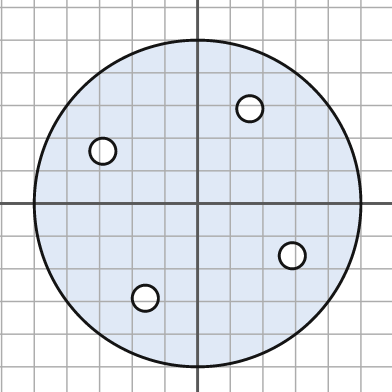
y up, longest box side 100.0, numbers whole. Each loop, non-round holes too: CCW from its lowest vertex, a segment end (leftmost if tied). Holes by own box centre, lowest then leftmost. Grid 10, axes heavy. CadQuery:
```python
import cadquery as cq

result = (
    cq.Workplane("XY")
    .moveTo(0.0, 0.0)
    .circle(50.0)
    .moveTo(-16.0, -29.0)
    .circle(4.0)
    .moveTo(29.0, -16.0)
    .circle(4.0)
    .moveTo(-29.0, 16.0)
    .circle(4.0)
    .moveTo(16.0, 29.0)
    .circle(4.0)
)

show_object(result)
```